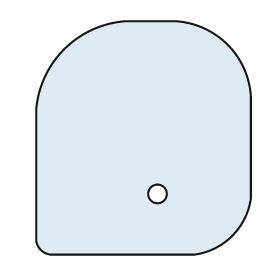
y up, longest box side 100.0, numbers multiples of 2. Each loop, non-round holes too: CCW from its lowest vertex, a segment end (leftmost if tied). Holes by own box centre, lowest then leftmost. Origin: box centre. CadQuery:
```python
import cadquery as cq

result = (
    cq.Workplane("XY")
    .moveTo(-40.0, -50.0)
    .lineTo(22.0, -50.0)
    .threePointArc((38.0, -42.0), (46.0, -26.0))
    .lineTo(46.0, 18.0)
    .threePointArc((36.0, 40.0), (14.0, 50.0))
    .lineTo(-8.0, 50.0)
    .threePointArc((-34.0, 38.0), (-46.0, 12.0))
    .lineTo(-46.0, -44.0)
    .threePointArc((-44.0, -48.0), (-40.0, -50.0))
    .close()
    .moveTo(6.0, -24.0)
    .circle(4.0)
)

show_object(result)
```